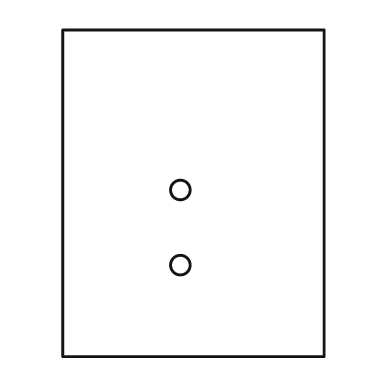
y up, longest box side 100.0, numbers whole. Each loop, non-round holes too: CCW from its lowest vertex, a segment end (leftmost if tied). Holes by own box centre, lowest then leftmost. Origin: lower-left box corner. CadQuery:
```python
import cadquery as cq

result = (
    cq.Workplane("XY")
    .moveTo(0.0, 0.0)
    .lineTo(80.0, 0.0)
    .lineTo(80.0, 100.0)
    .lineTo(0.0, 100.0)
    .close()
    .moveTo(36.0, 28.0)
    .circle(3.0)
    .moveTo(36.0, 51.0)
    .circle(3.0)
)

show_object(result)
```